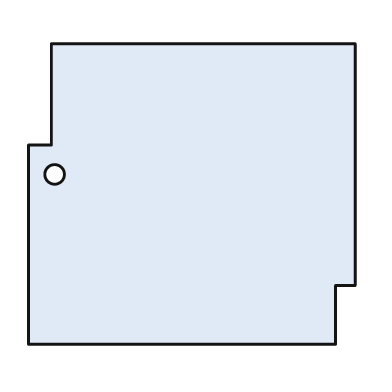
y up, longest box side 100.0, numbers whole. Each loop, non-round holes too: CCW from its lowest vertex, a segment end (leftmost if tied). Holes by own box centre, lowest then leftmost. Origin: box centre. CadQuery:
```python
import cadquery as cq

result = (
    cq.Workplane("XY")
    .moveTo(-50.0, -46.0)
    .lineTo(44.0, -46.0)
    .lineTo(44.0, -28.0)
    .lineTo(50.0, -28.0)
    .lineTo(50.0, 46.0)
    .lineTo(-43.0, 46.0)
    .lineTo(-43.0, 15.0)
    .lineTo(-50.0, 15.0)
    .close()
    .moveTo(-42.0, 6.0)
    .circle(3.0)
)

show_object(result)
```